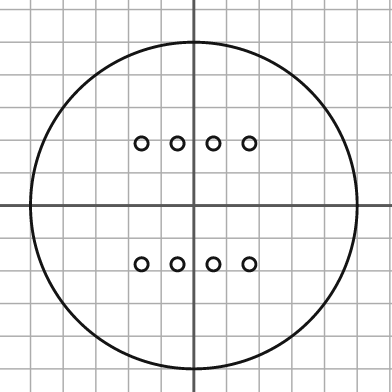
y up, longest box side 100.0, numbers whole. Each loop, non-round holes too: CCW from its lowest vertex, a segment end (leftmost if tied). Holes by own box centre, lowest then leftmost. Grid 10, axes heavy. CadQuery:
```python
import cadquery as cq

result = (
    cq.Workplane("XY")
    .moveTo(0.0, 0.0)
    .circle(50.0)
    .moveTo(-16.0, -18.0)
    .circle(2.0)
    .moveTo(-5.0, -18.0)
    .circle(2.0)
    .moveTo(6.0, -18.0)
    .circle(2.0)
    .moveTo(17.0, -18.0)
    .circle(2.0)
    .moveTo(-16.0, 19.0)
    .circle(2.0)
    .moveTo(-5.0, 19.0)
    .circle(2.0)
    .moveTo(6.0, 19.0)
    .circle(2.0)
    .moveTo(17.0, 19.0)
    .circle(2.0)
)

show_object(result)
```